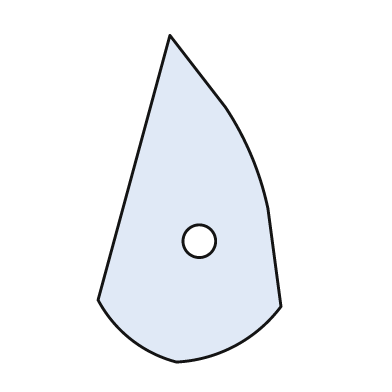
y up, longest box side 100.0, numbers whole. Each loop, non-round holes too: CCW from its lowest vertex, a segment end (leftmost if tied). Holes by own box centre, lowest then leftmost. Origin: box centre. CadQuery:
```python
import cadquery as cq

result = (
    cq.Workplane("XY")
    .moveTo(-4.0, -50.0)
    .threePointArc((14.0, -45.0), (28.0, -33.0))
    .lineTo(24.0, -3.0)
    .threePointArc((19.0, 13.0), (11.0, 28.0))
    .lineTo(-6.0, 50.0)
    .lineTo(-28.0, -31.0)
    .threePointArc((-18.0, -43.0), (-4.0, -50.0))
    .close()
    .moveTo(3.0, -13.0)
    .circle(5.0)
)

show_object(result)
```